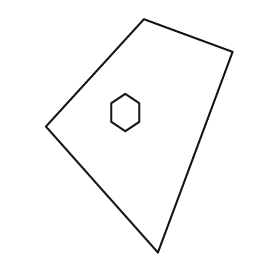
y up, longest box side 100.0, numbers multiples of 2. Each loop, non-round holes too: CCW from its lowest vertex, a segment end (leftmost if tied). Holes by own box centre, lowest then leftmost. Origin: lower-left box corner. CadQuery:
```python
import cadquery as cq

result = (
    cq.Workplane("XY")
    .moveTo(48.0, 0.0)
    .lineTo(80.0, 86.0)
    .lineTo(42.0, 100.0)
    .lineTo(0.0, 54.0)
    .close()
    .moveTo(34.0, 52.0)
    .lineTo(40.0, 56.0)
    .lineTo(40.0, 64.0)
    .lineTo(34.0, 68.0)
    .lineTo(28.0, 64.0)
    .lineTo(28.0, 56.0)
    .close()
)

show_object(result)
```